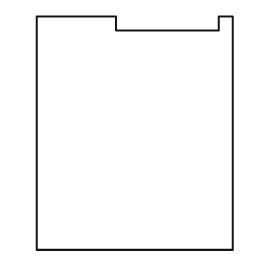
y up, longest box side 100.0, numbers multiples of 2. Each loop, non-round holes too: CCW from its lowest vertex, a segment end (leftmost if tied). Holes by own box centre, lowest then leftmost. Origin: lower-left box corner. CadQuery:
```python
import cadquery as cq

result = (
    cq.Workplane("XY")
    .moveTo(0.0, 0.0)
    .lineTo(84.0, 0.0)
    .lineTo(84.0, 100.0)
    .lineTo(78.0, 100.0)
    .lineTo(78.0, 94.0)
    .lineTo(34.0, 94.0)
    .lineTo(34.0, 100.0)
    .lineTo(0.0, 100.0)
    .close()
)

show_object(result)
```